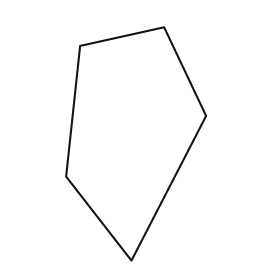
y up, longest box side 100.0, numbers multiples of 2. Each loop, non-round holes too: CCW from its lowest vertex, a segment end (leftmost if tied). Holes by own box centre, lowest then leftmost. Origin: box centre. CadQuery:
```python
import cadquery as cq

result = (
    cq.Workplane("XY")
    .moveTo(-2.0, -50.0)
    .lineTo(30.0, 12.0)
    .lineTo(12.0, 50.0)
    .lineTo(-24.0, 42.0)
    .lineTo(-30.0, -14.0)
    .close()
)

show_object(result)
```